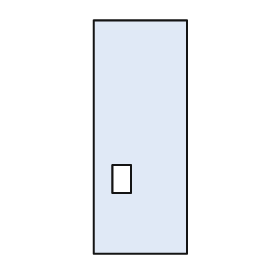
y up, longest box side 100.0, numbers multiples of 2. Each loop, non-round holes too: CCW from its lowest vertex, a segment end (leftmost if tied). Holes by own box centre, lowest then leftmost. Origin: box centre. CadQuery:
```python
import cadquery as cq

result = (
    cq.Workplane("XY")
    .moveTo(-20.0, -50.0)
    .lineTo(20.0, -50.0)
    .lineTo(20.0, 50.0)
    .lineTo(-20.0, 50.0)
    .close()
    .moveTo(-12.0, -24.0)
    .lineTo(-4.0, -24.0)
    .lineTo(-4.0, -12.0)
    .lineTo(-12.0, -12.0)
    .close()
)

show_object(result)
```